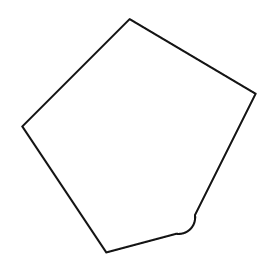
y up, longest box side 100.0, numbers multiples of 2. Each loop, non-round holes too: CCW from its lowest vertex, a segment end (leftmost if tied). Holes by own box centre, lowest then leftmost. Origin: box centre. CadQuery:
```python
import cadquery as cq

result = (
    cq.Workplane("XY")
    .moveTo(-14.0, -50.0)
    .lineTo(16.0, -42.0)
    .threePointArc((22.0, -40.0), (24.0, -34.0))
    .lineTo(50.0, 18.0)
    .lineTo(-4.0, 50.0)
    .lineTo(-50.0, 4.0)
    .close()
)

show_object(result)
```